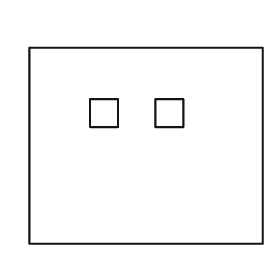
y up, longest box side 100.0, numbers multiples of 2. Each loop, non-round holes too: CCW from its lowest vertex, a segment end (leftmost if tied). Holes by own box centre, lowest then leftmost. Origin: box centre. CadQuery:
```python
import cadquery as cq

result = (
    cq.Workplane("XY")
    .moveTo(-50.0, -42.0)
    .lineTo(50.0, -42.0)
    .lineTo(50.0, 42.0)
    .lineTo(-50.0, 42.0)
    .close()
    .moveTo(-24.0, 8.0)
    .lineTo(-12.0, 8.0)
    .lineTo(-12.0, 20.0)
    .lineTo(-24.0, 20.0)
    .close()
    .moveTo(4.0, 8.0)
    .lineTo(16.0, 8.0)
    .lineTo(16.0, 20.0)
    .lineTo(4.0, 20.0)
    .close()
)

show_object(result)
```